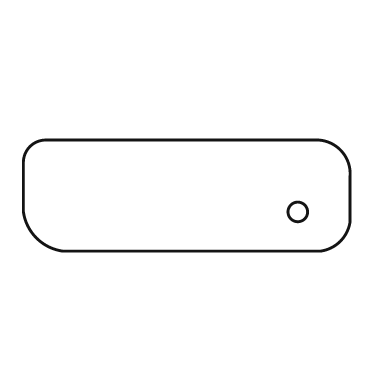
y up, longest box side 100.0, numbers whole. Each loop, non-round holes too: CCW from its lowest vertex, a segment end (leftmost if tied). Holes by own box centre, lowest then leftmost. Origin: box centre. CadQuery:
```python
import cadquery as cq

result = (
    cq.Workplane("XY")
    .moveTo(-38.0, -17.0)
    .lineTo(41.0, -17.0)
    .threePointArc((47.0, -14.0), (50.0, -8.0))
    .lineTo(50.0, 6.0)
    .threePointArc((47.0, 14.0), (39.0, 17.0))
    .lineTo(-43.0, 17.0)
    .threePointArc((-48.0, 15.0), (-50.0, 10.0))
    .lineTo(-50.0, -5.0)
    .threePointArc((-46.0, -13.0), (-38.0, -17.0))
    .close()
    .moveTo(34.0, -5.0)
    .circle(3.0)
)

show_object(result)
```